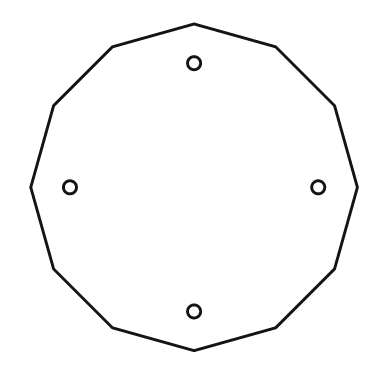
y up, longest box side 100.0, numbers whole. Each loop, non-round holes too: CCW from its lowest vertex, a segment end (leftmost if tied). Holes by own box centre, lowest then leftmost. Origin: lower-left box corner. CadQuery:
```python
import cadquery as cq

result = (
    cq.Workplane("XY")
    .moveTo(50.0, 0.0)
    .lineTo(75.0, 7.0)
    .lineTo(93.0, 25.0)
    .lineTo(100.0, 50.0)
    .lineTo(93.0, 75.0)
    .lineTo(75.0, 93.0)
    .lineTo(50.0, 100.0)
    .lineTo(25.0, 93.0)
    .lineTo(7.0, 75.0)
    .lineTo(0.0, 50.0)
    .lineTo(7.0, 25.0)
    .lineTo(25.0, 7.0)
    .close()
    .moveTo(50.0, 12.0)
    .circle(2.0)
    .moveTo(12.0, 50.0)
    .circle(2.0)
    .moveTo(88.0, 50.0)
    .circle(2.0)
    .moveTo(50.0, 88.0)
    .circle(2.0)
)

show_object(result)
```